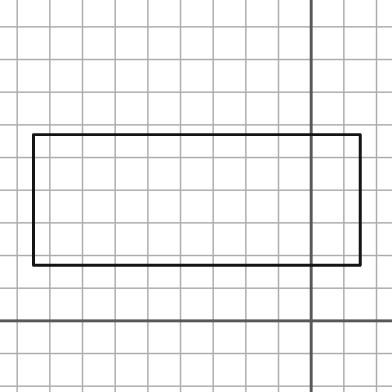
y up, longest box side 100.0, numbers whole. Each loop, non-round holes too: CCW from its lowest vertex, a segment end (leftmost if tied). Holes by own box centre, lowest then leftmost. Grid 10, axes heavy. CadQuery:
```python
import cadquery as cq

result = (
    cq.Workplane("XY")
    .moveTo(-85.0, 17.0)
    .lineTo(15.0, 17.0)
    .lineTo(15.0, 57.0)
    .lineTo(-85.0, 57.0)
    .close()
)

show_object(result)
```